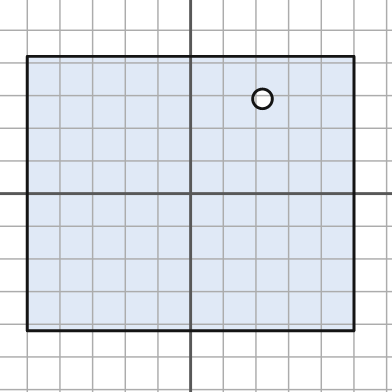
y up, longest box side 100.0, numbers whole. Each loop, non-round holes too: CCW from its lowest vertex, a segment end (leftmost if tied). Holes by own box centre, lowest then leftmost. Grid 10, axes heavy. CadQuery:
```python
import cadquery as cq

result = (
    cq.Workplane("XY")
    .moveTo(-50.0, -42.0)
    .lineTo(50.0, -42.0)
    .lineTo(50.0, 42.0)
    .lineTo(-50.0, 42.0)
    .close()
    .moveTo(22.0, 29.0)
    .circle(3.0)
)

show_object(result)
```